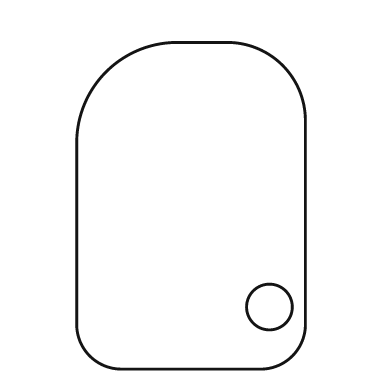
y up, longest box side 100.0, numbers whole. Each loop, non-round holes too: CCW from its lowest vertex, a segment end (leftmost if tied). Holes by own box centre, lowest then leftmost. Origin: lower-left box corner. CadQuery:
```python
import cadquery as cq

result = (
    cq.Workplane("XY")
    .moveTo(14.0, 0.0)
    .lineTo(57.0, 0.0)
    .threePointArc((66.0, 4.0), (70.0, 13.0))
    .lineTo(70.0, 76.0)
    .threePointArc((63.0, 93.0), (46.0, 100.0))
    .lineTo(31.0, 100.0)
    .threePointArc((9.0, 91.0), (0.0, 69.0))
    .lineTo(0.0, 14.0)
    .threePointArc((4.0, 4.0), (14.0, 0.0))
    .close()
    .moveTo(59.0, 19.0)
    .circle(7.0)
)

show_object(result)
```